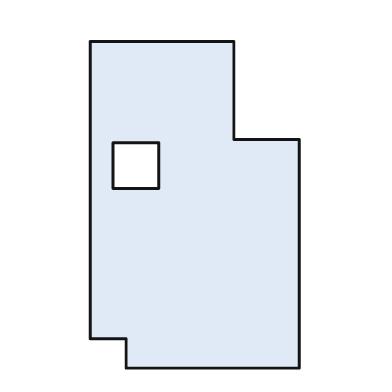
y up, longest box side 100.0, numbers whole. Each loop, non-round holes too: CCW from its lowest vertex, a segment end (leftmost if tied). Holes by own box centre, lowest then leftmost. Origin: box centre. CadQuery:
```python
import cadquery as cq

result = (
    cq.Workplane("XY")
    .moveTo(-21.0, -50.0)
    .lineTo(32.0, -50.0)
    .lineTo(32.0, 20.0)
    .lineTo(12.0, 20.0)
    .lineTo(12.0, 50.0)
    .lineTo(-32.0, 50.0)
    .lineTo(-32.0, -41.0)
    .lineTo(-21.0, -41.0)
    .close()
    .moveTo(-25.0, 5.0)
    .lineTo(-11.0, 5.0)
    .lineTo(-11.0, 19.0)
    .lineTo(-25.0, 19.0)
    .close()
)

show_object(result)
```